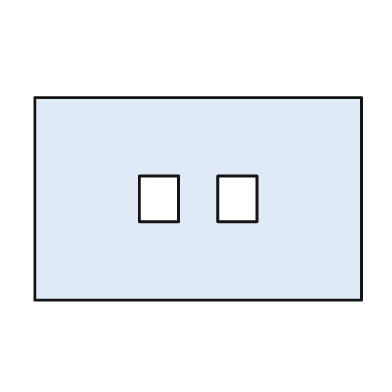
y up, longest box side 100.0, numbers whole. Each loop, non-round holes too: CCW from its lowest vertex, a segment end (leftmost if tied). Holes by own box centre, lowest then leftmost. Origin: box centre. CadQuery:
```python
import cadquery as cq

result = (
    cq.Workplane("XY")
    .moveTo(-50.0, -31.0)
    .lineTo(50.0, -31.0)
    .lineTo(50.0, 31.0)
    .lineTo(-50.0, 31.0)
    .close()
    .moveTo(-18.0, -7.0)
    .lineTo(-6.0, -7.0)
    .lineTo(-6.0, 7.0)
    .lineTo(-18.0, 7.0)
    .close()
    .moveTo(6.0, -7.0)
    .lineTo(18.0, -7.0)
    .lineTo(18.0, 7.0)
    .lineTo(6.0, 7.0)
    .close()
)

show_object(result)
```